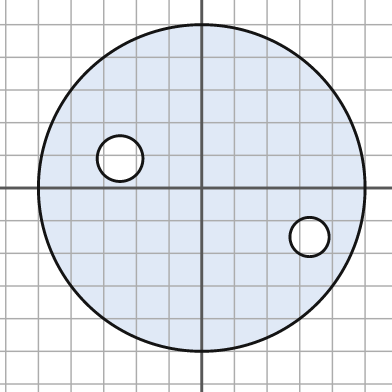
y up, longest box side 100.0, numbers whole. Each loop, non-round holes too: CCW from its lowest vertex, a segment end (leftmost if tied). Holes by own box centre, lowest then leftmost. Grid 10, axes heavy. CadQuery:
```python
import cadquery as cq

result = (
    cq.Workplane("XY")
    .moveTo(0.0, 0.0)
    .circle(50.0)
    .moveTo(33.0, -15.0)
    .circle(6.0)
    .moveTo(-25.0, 9.0)
    .circle(7.0)
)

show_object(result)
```